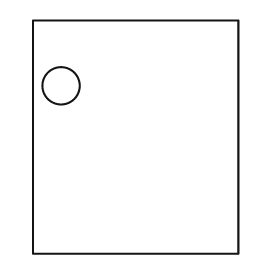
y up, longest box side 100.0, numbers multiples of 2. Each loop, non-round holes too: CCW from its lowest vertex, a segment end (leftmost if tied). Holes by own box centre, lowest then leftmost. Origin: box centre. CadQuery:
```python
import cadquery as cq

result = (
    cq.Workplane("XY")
    .moveTo(-44.0, -50.0)
    .lineTo(44.0, -50.0)
    .lineTo(44.0, 50.0)
    .lineTo(-44.0, 50.0)
    .close()
    .moveTo(-32.0, 22.0)
    .circle(8.0)
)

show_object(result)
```